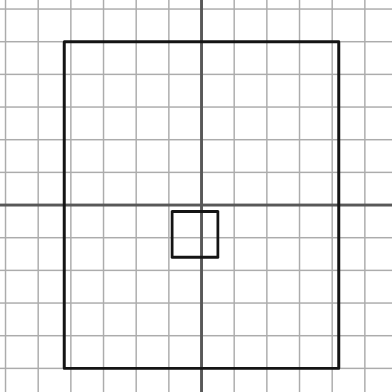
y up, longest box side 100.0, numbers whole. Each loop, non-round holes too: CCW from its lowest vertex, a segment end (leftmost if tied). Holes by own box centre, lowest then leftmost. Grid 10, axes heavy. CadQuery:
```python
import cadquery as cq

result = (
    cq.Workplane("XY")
    .moveTo(-42.0, -50.0)
    .lineTo(42.0, -50.0)
    .lineTo(42.0, 50.0)
    .lineTo(-42.0, 50.0)
    .close()
    .moveTo(-9.0, -16.0)
    .lineTo(5.0, -16.0)
    .lineTo(5.0, -2.0)
    .lineTo(-9.0, -2.0)
    .close()
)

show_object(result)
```